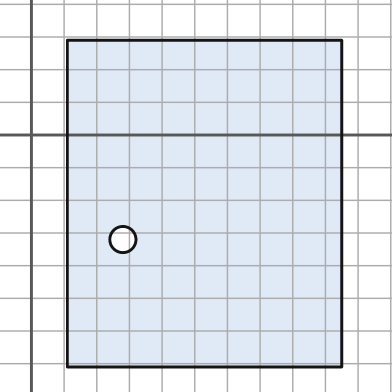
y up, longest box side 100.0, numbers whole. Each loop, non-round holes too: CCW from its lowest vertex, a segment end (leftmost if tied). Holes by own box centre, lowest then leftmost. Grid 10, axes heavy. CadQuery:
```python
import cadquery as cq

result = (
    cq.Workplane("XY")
    .moveTo(11.0, -71.0)
    .lineTo(95.0, -71.0)
    .lineTo(95.0, 29.0)
    .lineTo(11.0, 29.0)
    .close()
    .moveTo(28.0, -32.0)
    .circle(4.0)
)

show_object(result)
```